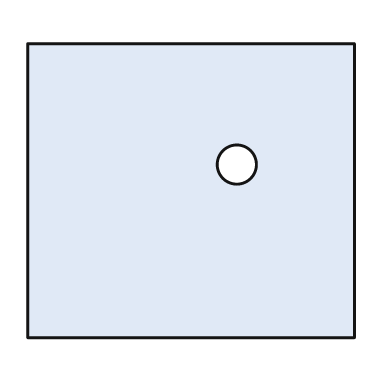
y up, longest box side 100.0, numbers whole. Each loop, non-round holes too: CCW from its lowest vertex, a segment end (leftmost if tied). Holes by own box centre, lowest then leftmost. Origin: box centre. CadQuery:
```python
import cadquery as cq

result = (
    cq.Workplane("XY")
    .moveTo(-50.0, -45.0)
    .lineTo(50.0, -45.0)
    .lineTo(50.0, 45.0)
    .lineTo(-50.0, 45.0)
    .close()
    .moveTo(14.0, 8.0)
    .circle(6.0)
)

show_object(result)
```